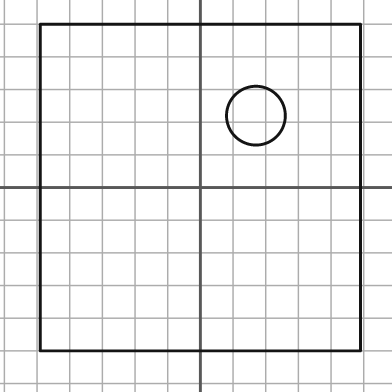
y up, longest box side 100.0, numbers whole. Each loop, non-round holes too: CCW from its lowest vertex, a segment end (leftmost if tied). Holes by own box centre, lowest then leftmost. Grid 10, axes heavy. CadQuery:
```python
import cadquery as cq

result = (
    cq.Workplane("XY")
    .moveTo(-49.0, -50.0)
    .lineTo(49.0, -50.0)
    .lineTo(49.0, 50.0)
    .lineTo(-49.0, 50.0)
    .close()
    .moveTo(17.0, 22.0)
    .circle(9.0)
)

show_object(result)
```